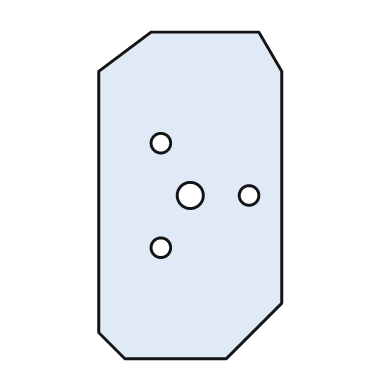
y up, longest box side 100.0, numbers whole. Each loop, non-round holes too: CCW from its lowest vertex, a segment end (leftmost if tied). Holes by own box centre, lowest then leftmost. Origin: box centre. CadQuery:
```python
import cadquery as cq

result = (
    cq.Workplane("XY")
    .moveTo(-20.0, -50.0)
    .lineTo(11.0, -50.0)
    .lineTo(28.0, -33.0)
    .lineTo(28.0, 38.0)
    .lineTo(21.0, 50.0)
    .lineTo(-12.0, 50.0)
    .lineTo(-28.0, 38.0)
    .lineTo(-28.0, -42.0)
    .close()
    .moveTo(-9.0, -16.0)
    .circle(3.0)
    .moveTo(0.0, 0.0)
    .circle(4.0)
    .moveTo(18.0, 0.0)
    .circle(3.0)
    .moveTo(-9.0, 16.0)
    .circle(3.0)
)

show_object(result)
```